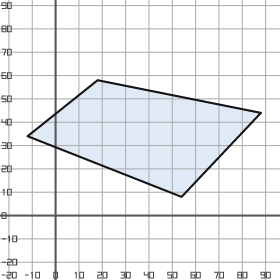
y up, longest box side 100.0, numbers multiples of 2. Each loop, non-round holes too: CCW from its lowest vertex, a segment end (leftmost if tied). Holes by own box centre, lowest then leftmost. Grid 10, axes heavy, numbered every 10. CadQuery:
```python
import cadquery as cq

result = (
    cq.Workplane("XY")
    .moveTo(54.0, 8.0)
    .lineTo(88.0, 44.0)
    .lineTo(18.0, 58.0)
    .lineTo(-12.0, 34.0)
    .close()
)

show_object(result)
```